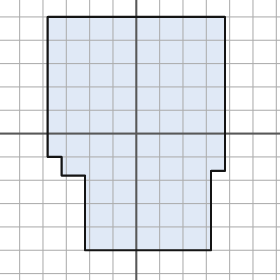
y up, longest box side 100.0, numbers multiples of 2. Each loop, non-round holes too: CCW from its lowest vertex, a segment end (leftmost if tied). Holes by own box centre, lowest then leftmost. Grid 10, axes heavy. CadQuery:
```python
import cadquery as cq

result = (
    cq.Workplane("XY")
    .moveTo(-22.0, -50.0)
    .lineTo(32.0, -50.0)
    .lineTo(32.0, -16.0)
    .lineTo(38.0, -16.0)
    .lineTo(38.0, 50.0)
    .lineTo(-38.0, 50.0)
    .lineTo(-38.0, -10.0)
    .lineTo(-32.0, -10.0)
    .lineTo(-32.0, -18.0)
    .lineTo(-22.0, -18.0)
    .close()
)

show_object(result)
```